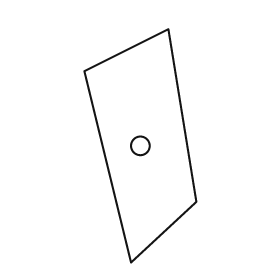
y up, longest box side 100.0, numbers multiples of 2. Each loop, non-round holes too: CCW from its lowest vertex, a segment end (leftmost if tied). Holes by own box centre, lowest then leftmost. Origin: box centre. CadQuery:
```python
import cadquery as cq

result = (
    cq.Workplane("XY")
    .moveTo(-4.0, -50.0)
    .lineTo(24.0, -24.0)
    .lineTo(12.0, 50.0)
    .lineTo(-24.0, 32.0)
    .close()
    .moveTo(0.0, 0.0)
    .circle(4.0)
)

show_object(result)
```